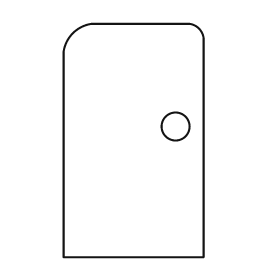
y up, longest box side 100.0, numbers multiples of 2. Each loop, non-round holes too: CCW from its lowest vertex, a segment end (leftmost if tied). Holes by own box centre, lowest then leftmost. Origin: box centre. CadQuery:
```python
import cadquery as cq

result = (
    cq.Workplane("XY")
    .moveTo(-30.0, -50.0)
    .lineTo(30.0, -50.0)
    .lineTo(30.0, 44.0)
    .threePointArc((28.0, 48.0), (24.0, 50.0))
    .lineTo(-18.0, 50.0)
    .threePointArc((-26.0, 46.0), (-30.0, 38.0))
    .close()
    .moveTo(18.0, 6.0)
    .circle(6.0)
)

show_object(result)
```